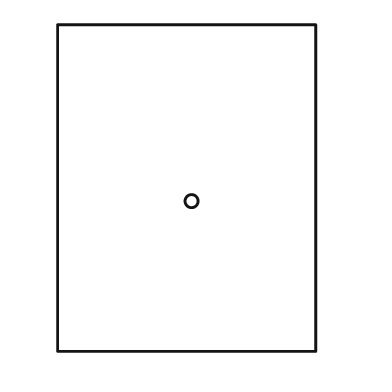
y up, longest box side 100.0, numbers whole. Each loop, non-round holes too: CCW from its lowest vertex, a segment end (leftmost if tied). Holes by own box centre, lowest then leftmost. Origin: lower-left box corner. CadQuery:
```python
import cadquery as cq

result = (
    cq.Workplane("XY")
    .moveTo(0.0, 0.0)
    .lineTo(79.0, 0.0)
    .lineTo(79.0, 100.0)
    .lineTo(0.0, 100.0)
    .close()
    .moveTo(41.0, 46.0)
    .circle(2.0)
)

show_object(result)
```